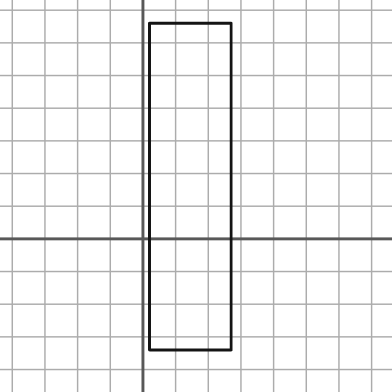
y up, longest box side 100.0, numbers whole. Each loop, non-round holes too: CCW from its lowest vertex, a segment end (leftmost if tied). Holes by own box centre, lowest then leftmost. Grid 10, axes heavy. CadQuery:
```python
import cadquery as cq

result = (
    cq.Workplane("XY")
    .moveTo(2.0, -34.0)
    .lineTo(27.0, -34.0)
    .lineTo(27.0, 66.0)
    .lineTo(2.0, 66.0)
    .close()
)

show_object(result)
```